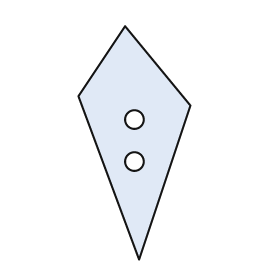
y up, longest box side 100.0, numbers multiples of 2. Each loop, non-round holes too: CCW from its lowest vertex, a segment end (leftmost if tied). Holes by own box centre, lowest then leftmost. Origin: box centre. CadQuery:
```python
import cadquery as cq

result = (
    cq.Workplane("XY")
    .moveTo(2.0, -50.0)
    .lineTo(24.0, 16.0)
    .lineTo(-4.0, 50.0)
    .lineTo(-24.0, 20.0)
    .close()
    .moveTo(0.0, -8.0)
    .circle(4.0)
    .moveTo(0.0, 10.0)
    .circle(4.0)
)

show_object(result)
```